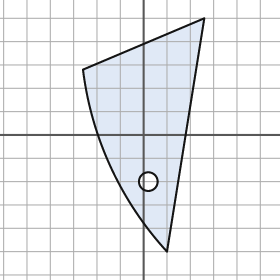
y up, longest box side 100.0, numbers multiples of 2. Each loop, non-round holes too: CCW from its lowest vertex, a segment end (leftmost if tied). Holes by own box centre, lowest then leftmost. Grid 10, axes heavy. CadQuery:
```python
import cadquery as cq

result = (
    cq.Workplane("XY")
    .moveTo(10.0, -50.0)
    .lineTo(26.0, 50.0)
    .lineTo(-26.0, 28.0)
    .threePointArc((-14.0, -14.0), (10.0, -50.0))
    .close()
    .moveTo(2.0, -20.0)
    .circle(4.0)
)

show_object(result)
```